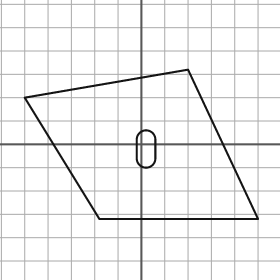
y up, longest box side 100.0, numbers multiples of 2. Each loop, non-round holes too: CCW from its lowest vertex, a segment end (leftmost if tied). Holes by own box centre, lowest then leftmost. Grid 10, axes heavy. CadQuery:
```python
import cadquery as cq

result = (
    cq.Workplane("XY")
    .moveTo(-18.0, -32.0)
    .lineTo(50.0, -32.0)
    .lineTo(20.0, 32.0)
    .lineTo(-50.0, 20.0)
    .close()
    .moveTo(-2.0, -6.0)
    .threePointArc((2.0, -10.0), (6.0, -6.0))
    .lineTo(6.0, 2.0)
    .threePointArc((2.0, 6.0), (-2.0, 2.0))
    .close()
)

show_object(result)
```